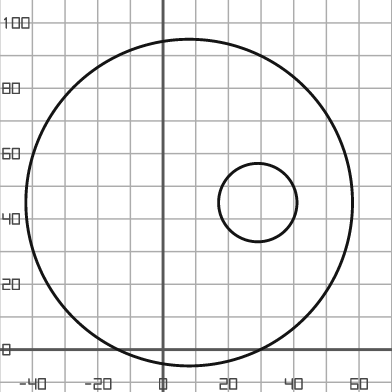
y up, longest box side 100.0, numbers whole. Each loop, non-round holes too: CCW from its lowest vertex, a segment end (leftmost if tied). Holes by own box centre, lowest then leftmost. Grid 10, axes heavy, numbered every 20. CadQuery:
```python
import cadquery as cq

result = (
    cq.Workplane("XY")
    .moveTo(8.0, 45.0)
    .circle(50.0)
    .moveTo(29.0, 45.0)
    .circle(12.0)
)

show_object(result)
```